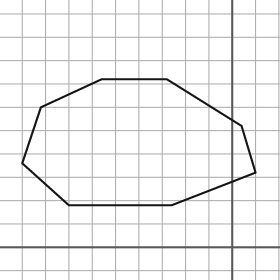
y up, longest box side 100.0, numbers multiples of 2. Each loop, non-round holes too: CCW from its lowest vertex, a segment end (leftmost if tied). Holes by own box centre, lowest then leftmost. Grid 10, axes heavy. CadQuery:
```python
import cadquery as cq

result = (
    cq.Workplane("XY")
    .moveTo(-70.0, 18.0)
    .lineTo(-26.0, 18.0)
    .lineTo(10.0, 32.0)
    .lineTo(4.0, 52.0)
    .lineTo(-28.0, 72.0)
    .lineTo(-56.0, 72.0)
    .lineTo(-82.0, 60.0)
    .lineTo(-90.0, 36.0)
    .close()
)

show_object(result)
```